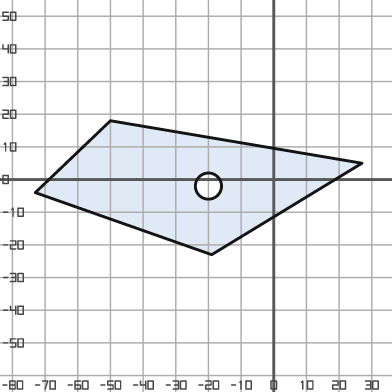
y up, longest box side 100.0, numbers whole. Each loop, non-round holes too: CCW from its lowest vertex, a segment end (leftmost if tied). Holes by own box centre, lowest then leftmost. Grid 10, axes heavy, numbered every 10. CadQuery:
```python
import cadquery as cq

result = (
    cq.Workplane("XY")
    .moveTo(-19.0, -23.0)
    .lineTo(27.0, 5.0)
    .lineTo(-50.0, 18.0)
    .lineTo(-73.0, -4.0)
    .close()
    .moveTo(-20.0, -2.0)
    .circle(4.0)
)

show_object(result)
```